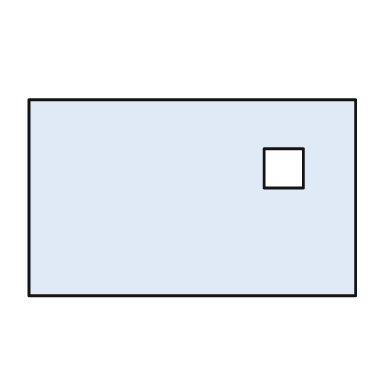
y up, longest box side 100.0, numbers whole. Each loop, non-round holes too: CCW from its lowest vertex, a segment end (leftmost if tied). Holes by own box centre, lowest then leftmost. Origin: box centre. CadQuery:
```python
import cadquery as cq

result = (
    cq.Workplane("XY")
    .moveTo(-50.0, -30.0)
    .lineTo(50.0, -30.0)
    .lineTo(50.0, 30.0)
    .lineTo(-50.0, 30.0)
    .close()
    .moveTo(22.0, 3.0)
    .lineTo(34.0, 3.0)
    .lineTo(34.0, 15.0)
    .lineTo(22.0, 15.0)
    .close()
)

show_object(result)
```